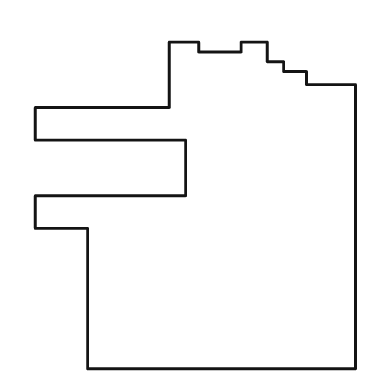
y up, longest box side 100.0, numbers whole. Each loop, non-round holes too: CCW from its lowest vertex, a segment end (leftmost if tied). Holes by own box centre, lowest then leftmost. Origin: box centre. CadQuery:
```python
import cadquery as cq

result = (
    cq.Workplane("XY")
    .moveTo(-33.0, -50.0)
    .lineTo(49.0, -50.0)
    .lineTo(49.0, 37.0)
    .lineTo(34.0, 37.0)
    .lineTo(34.0, 41.0)
    .lineTo(27.0, 41.0)
    .lineTo(27.0, 44.0)
    .lineTo(22.0, 44.0)
    .lineTo(22.0, 50.0)
    .lineTo(14.0, 50.0)
    .lineTo(14.0, 47.0)
    .lineTo(1.0, 47.0)
    .lineTo(1.0, 50.0)
    .lineTo(-8.0, 50.0)
    .lineTo(-8.0, 30.0)
    .lineTo(-49.0, 30.0)
    .lineTo(-49.0, 20.0)
    .lineTo(-3.0, 20.0)
    .lineTo(-3.0, 3.0)
    .lineTo(-49.0, 3.0)
    .lineTo(-49.0, -7.0)
    .lineTo(-33.0, -7.0)
    .close()
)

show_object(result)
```